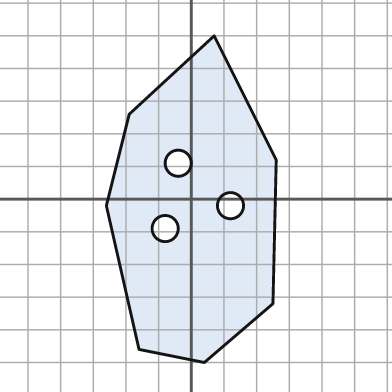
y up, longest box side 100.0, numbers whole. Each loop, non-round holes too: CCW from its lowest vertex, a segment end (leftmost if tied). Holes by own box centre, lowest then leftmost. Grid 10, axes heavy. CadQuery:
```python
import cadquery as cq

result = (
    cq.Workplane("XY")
    .moveTo(4.0, -50.0)
    .lineTo(25.0, -32.0)
    .lineTo(26.0, 12.0)
    .lineTo(7.0, 50.0)
    .lineTo(-19.0, 26.0)
    .lineTo(-26.0, -2.0)
    .lineTo(-16.0, -46.0)
    .close()
    .moveTo(-8.0, -9.0)
    .circle(4.0)
    .moveTo(12.0, -2.0)
    .circle(4.0)
    .moveTo(-4.0, 11.0)
    .circle(4.0)
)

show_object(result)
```